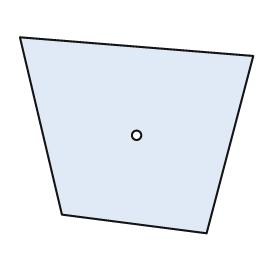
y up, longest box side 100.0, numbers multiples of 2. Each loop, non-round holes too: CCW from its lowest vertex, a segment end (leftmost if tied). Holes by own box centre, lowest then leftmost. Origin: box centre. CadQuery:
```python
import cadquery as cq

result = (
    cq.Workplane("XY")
    .moveTo(30.0, -42.0)
    .lineTo(50.0, 34.0)
    .lineTo(-50.0, 42.0)
    .lineTo(-32.0, -34.0)
    .close()
    .moveTo(0.0, 0.0)
    .circle(2.0)
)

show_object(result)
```